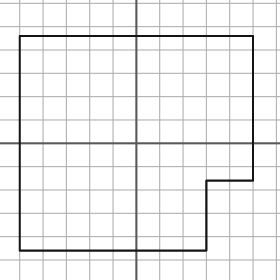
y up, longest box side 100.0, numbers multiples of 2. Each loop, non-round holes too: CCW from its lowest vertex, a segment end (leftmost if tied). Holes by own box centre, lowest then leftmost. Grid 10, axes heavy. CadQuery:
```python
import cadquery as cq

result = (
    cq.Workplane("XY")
    .moveTo(-50.0, -46.0)
    .lineTo(30.0, -46.0)
    .lineTo(30.0, -16.0)
    .lineTo(50.0, -16.0)
    .lineTo(50.0, 46.0)
    .lineTo(-50.0, 46.0)
    .close()
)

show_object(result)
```